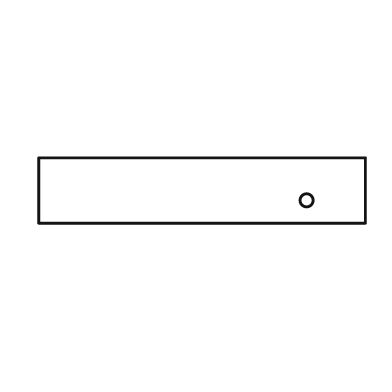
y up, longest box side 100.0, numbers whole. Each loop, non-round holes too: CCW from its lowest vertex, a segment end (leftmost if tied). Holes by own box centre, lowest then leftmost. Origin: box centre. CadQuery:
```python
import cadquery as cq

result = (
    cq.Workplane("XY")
    .moveTo(-50.0, -10.0)
    .lineTo(50.0, -10.0)
    .lineTo(50.0, 10.0)
    .lineTo(-50.0, 10.0)
    .close()
    .moveTo(32.0, -3.0)
    .circle(2.0)
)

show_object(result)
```